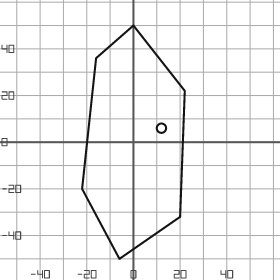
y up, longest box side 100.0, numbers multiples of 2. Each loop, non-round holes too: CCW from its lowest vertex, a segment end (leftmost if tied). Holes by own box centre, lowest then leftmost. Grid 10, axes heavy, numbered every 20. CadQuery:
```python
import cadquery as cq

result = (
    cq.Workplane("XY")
    .moveTo(-6.0, -50.0)
    .lineTo(20.0, -32.0)
    .lineTo(22.0, 22.0)
    .lineTo(0.0, 50.0)
    .lineTo(-16.0, 36.0)
    .lineTo(-22.0, -20.0)
    .close()
    .moveTo(12.0, 6.0)
    .circle(2.0)
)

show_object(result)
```